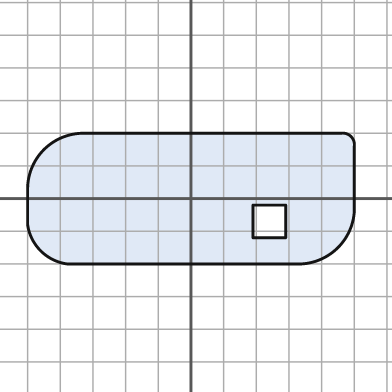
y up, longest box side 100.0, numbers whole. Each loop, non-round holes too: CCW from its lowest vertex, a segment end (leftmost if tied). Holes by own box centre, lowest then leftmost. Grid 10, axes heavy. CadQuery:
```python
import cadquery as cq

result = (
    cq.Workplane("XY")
    .moveTo(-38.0, -20.0)
    .lineTo(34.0, -20.0)
    .threePointArc((45.0, -15.0), (50.0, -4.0))
    .lineTo(50.0, 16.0)
    .threePointArc((49.0, 19.0), (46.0, 20.0))
    .lineTo(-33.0, 20.0)
    .threePointArc((-45.0, 15.0), (-50.0, 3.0))
    .lineTo(-50.0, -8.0)
    .threePointArc((-46.0, -16.0), (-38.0, -20.0))
    .close()
    .moveTo(19.0, -12.0)
    .lineTo(29.0, -12.0)
    .lineTo(29.0, -2.0)
    .lineTo(19.0, -2.0)
    .close()
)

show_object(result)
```